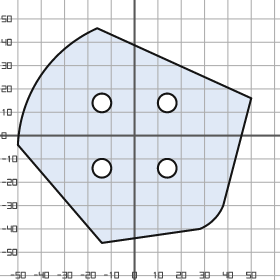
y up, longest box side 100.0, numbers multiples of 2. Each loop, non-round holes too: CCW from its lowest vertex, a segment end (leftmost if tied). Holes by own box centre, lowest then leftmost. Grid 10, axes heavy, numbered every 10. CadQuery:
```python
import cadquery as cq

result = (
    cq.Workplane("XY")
    .moveTo(-14.0, -46.0)
    .lineTo(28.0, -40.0)
    .threePointArc((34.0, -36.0), (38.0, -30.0))
    .lineTo(50.0, 16.0)
    .lineTo(-16.0, 46.0)
    .threePointArc((-40.0, 26.0), (-50.0, -4.0))
    .close()
    .moveTo(-14.0, -14.0)
    .circle(4.0)
    .moveTo(14.0, -14.0)
    .circle(4.0)
    .moveTo(-14.0, 14.0)
    .circle(4.0)
    .moveTo(14.0, 14.0)
    .circle(4.0)
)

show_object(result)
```